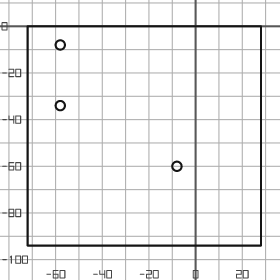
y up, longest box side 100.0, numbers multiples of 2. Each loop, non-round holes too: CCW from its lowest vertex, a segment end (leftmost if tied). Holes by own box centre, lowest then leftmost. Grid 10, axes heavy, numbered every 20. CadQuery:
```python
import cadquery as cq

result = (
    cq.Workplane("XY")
    .moveTo(-72.0, -94.0)
    .lineTo(28.0, -94.0)
    .lineTo(28.0, 0.0)
    .lineTo(-72.0, 0.0)
    .close()
    .moveTo(-8.0, -60.0)
    .circle(2.0)
    .moveTo(-58.0, -34.0)
    .circle(2.0)
    .moveTo(-58.0, -8.0)
    .circle(2.0)
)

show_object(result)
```